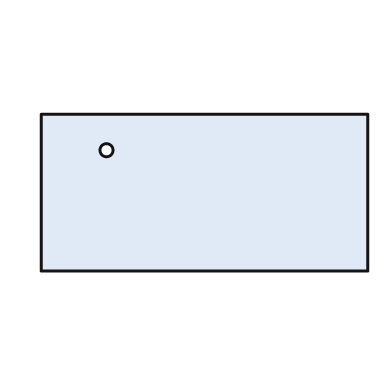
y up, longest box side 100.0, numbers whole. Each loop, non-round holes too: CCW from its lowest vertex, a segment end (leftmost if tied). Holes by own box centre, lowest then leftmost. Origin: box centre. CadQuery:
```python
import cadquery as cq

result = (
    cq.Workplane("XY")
    .moveTo(-50.0, -24.0)
    .lineTo(50.0, -24.0)
    .lineTo(50.0, 24.0)
    .lineTo(-50.0, 24.0)
    .close()
    .moveTo(-30.0, 13.0)
    .circle(2.0)
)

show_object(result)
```